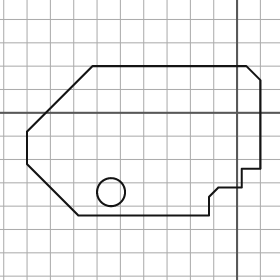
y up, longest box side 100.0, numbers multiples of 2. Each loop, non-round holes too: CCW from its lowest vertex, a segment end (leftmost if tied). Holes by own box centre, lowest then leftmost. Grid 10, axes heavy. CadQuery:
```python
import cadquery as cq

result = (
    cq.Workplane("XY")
    .moveTo(-68.0, -44.0)
    .lineTo(-12.0, -44.0)
    .lineTo(-12.0, -36.0)
    .lineTo(-8.0, -32.0)
    .lineTo(2.0, -32.0)
    .lineTo(2.0, -24.0)
    .lineTo(10.0, -24.0)
    .lineTo(10.0, 14.0)
    .lineTo(4.0, 20.0)
    .lineTo(-62.0, 20.0)
    .lineTo(-90.0, -8.0)
    .lineTo(-90.0, -22.0)
    .close()
    .moveTo(-54.0, -34.0)
    .circle(6.0)
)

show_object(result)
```